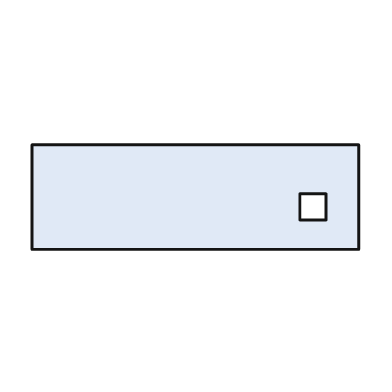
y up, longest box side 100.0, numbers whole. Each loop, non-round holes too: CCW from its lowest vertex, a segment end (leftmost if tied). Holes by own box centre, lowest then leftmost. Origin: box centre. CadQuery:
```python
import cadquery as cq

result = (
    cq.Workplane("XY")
    .moveTo(-50.0, -16.0)
    .lineTo(50.0, -16.0)
    .lineTo(50.0, 16.0)
    .lineTo(-50.0, 16.0)
    .close()
    .moveTo(32.0, -7.0)
    .lineTo(40.0, -7.0)
    .lineTo(40.0, 1.0)
    .lineTo(32.0, 1.0)
    .close()
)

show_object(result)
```